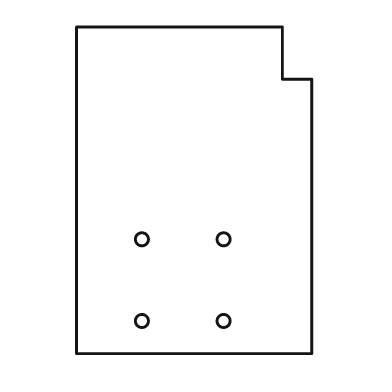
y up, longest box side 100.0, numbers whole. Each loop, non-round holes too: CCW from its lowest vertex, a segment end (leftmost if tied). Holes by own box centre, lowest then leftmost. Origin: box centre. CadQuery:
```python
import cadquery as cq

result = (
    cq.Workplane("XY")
    .moveTo(-36.0, -50.0)
    .lineTo(36.0, -50.0)
    .lineTo(36.0, 34.0)
    .lineTo(27.0, 34.0)
    .lineTo(27.0, 50.0)
    .lineTo(-36.0, 50.0)
    .close()
    .moveTo(-16.0, -40.0)
    .circle(2.0)
    .moveTo(9.0, -40.0)
    .circle(2.0)
    .moveTo(-16.0, -15.0)
    .circle(2.0)
    .moveTo(9.0, -15.0)
    .circle(2.0)
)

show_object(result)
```